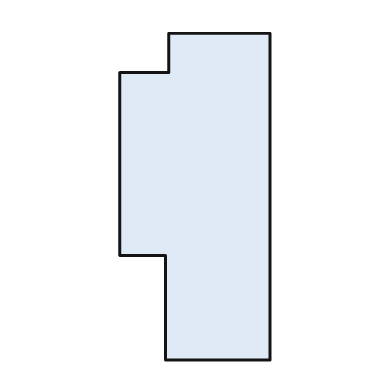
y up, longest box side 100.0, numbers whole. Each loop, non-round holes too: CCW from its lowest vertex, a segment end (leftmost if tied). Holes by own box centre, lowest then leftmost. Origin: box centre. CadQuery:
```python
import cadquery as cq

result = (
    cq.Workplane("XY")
    .moveTo(-9.0, -50.0)
    .lineTo(23.0, -50.0)
    .lineTo(23.0, 50.0)
    .lineTo(-8.0, 50.0)
    .lineTo(-8.0, 38.0)
    .lineTo(-23.0, 38.0)
    .lineTo(-23.0, -18.0)
    .lineTo(-9.0, -18.0)
    .close()
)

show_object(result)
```